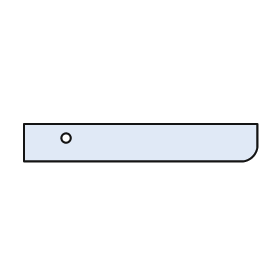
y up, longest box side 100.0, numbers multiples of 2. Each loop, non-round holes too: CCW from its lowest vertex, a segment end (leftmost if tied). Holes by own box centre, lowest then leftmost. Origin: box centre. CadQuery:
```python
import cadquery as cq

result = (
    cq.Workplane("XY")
    .moveTo(-50.0, -8.0)
    .lineTo(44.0, -8.0)
    .threePointArc((48.0, -6.0), (50.0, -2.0))
    .lineTo(50.0, 8.0)
    .lineTo(-50.0, 8.0)
    .close()
    .moveTo(-32.0, 2.0)
    .circle(2.0)
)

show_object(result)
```